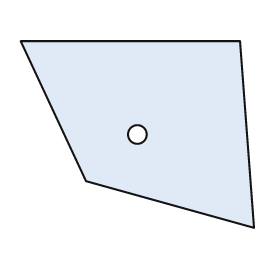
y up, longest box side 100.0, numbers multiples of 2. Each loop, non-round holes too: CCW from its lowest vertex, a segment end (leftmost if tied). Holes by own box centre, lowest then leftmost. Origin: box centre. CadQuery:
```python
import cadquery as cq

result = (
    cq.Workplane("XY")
    .moveTo(50.0, -40.0)
    .lineTo(44.0, 40.0)
    .lineTo(-50.0, 40.0)
    .lineTo(-22.0, -20.0)
    .close()
    .moveTo(0.0, 0.0)
    .circle(4.0)
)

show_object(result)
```